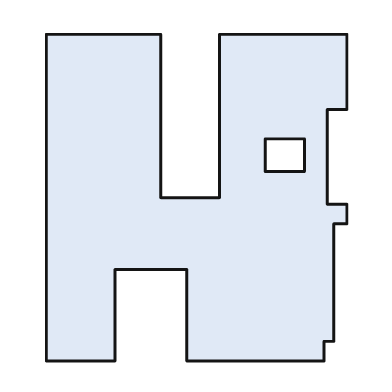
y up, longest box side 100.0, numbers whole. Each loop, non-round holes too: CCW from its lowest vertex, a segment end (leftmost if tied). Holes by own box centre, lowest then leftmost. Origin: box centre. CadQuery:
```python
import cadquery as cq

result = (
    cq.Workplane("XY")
    .moveTo(-46.0, -50.0)
    .lineTo(-25.0, -50.0)
    .lineTo(-25.0, -22.0)
    .lineTo(-3.0, -22.0)
    .lineTo(-3.0, -50.0)
    .lineTo(39.0, -50.0)
    .lineTo(39.0, -44.0)
    .lineTo(42.0, -44.0)
    .lineTo(42.0, -8.0)
    .lineTo(46.0, -8.0)
    .lineTo(46.0, -2.0)
    .lineTo(40.0, -2.0)
    .lineTo(40.0, 27.0)
    .lineTo(46.0, 27.0)
    .lineTo(46.0, 50.0)
    .lineTo(7.0, 50.0)
    .lineTo(7.0, 0.0)
    .lineTo(-11.0, 0.0)
    .lineTo(-11.0, 50.0)
    .lineTo(-46.0, 50.0)
    .close()
    .moveTo(21.0, 8.0)
    .lineTo(33.0, 8.0)
    .lineTo(33.0, 18.0)
    .lineTo(21.0, 18.0)
    .close()
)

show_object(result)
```